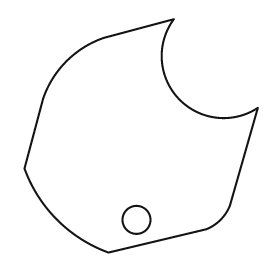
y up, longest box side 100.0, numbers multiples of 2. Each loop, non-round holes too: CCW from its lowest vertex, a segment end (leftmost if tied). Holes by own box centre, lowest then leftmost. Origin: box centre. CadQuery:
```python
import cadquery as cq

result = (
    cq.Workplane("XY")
    .moveTo(-14.0, -50.0)
    .lineTo(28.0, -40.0)
    .threePointArc((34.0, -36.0), (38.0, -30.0))
    .lineTo(50.0, 12.0)
    .threePointArc((16.0, 16.0), (14.0, 50.0))
    .lineTo(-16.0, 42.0)
    .threePointArc((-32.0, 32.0), (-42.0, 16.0))
    .lineTo(-50.0, -14.0)
    .threePointArc((-36.0, -36.0), (-14.0, -50.0))
    .close()
    .moveTo(-2.0, -36.0)
    .circle(6.0)
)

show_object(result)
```